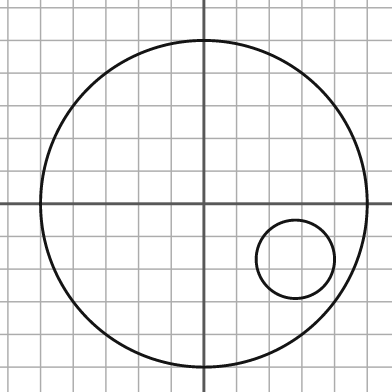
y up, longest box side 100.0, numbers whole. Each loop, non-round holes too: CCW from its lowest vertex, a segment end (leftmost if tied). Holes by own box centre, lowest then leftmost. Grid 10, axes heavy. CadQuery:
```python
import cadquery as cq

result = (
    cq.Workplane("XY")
    .moveTo(0.0, 0.0)
    .circle(50.0)
    .moveTo(28.0, -17.0)
    .circle(12.0)
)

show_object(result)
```